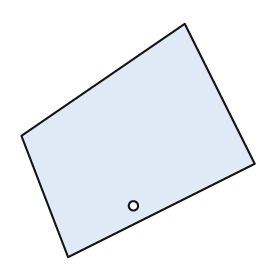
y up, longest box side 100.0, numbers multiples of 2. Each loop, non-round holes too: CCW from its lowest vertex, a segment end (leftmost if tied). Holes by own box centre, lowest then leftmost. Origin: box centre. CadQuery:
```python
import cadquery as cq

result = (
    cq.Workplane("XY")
    .moveTo(-30.0, -50.0)
    .lineTo(50.0, -10.0)
    .lineTo(20.0, 50.0)
    .lineTo(-50.0, 2.0)
    .close()
    .moveTo(-2.0, -28.0)
    .circle(2.0)
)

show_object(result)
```